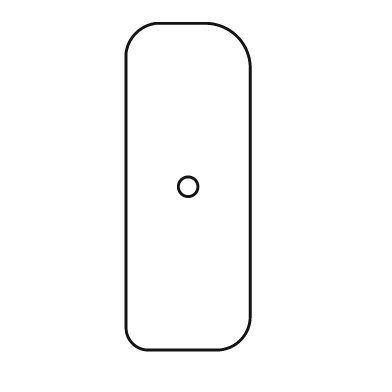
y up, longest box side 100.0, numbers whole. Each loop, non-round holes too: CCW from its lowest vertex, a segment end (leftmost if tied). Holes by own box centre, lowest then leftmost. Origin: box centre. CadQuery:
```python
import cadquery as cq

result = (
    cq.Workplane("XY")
    .moveTo(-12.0, -50.0)
    .lineTo(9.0, -50.0)
    .threePointArc((16.0, -47.0), (19.0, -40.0))
    .lineTo(19.0, 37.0)
    .threePointArc((15.0, 46.0), (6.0, 50.0))
    .lineTo(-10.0, 50.0)
    .threePointArc((-16.0, 47.0), (-19.0, 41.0))
    .lineTo(-19.0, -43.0)
    .threePointArc((-17.0, -48.0), (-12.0, -50.0))
    .close()
    .moveTo(0.0, 0.0)
    .circle(3.0)
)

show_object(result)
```